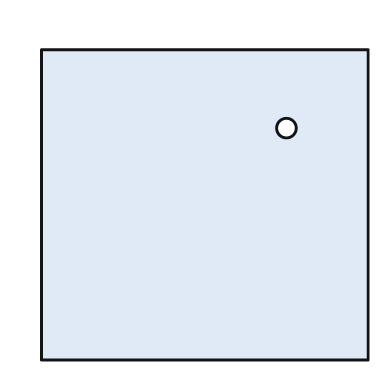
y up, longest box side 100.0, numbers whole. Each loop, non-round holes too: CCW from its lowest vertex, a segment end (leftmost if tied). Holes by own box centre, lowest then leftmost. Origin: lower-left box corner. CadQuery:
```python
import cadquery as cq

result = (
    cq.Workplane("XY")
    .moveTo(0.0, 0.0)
    .lineTo(100.0, 0.0)
    .lineTo(100.0, 95.0)
    .lineTo(0.0, 95.0)
    .close()
    .moveTo(75.0, 71.0)
    .circle(3.0)
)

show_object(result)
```